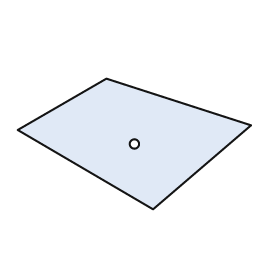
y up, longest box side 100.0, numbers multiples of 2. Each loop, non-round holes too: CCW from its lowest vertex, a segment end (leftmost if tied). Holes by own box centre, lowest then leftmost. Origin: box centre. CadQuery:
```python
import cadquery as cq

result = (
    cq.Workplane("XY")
    .moveTo(8.0, -28.0)
    .lineTo(50.0, 8.0)
    .lineTo(-12.0, 28.0)
    .lineTo(-50.0, 6.0)
    .close()
    .moveTo(0.0, 0.0)
    .circle(2.0)
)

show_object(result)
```